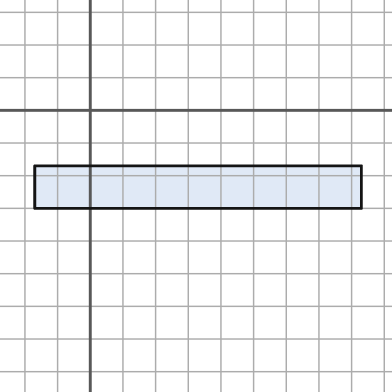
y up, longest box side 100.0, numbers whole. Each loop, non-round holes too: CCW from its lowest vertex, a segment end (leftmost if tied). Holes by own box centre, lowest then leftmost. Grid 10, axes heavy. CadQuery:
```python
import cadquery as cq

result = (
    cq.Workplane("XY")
    .moveTo(-17.0, -30.0)
    .lineTo(83.0, -30.0)
    .lineTo(83.0, -17.0)
    .lineTo(-17.0, -17.0)
    .close()
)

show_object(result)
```